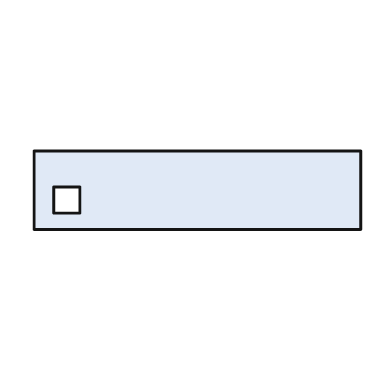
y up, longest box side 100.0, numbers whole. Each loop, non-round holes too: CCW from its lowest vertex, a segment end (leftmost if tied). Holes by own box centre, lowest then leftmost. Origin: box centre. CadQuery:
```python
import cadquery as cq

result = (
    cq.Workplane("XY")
    .moveTo(-50.0, -12.0)
    .lineTo(50.0, -12.0)
    .lineTo(50.0, 12.0)
    .lineTo(-50.0, 12.0)
    .close()
    .moveTo(-44.0, -7.0)
    .lineTo(-36.0, -7.0)
    .lineTo(-36.0, 1.0)
    .lineTo(-44.0, 1.0)
    .close()
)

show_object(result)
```